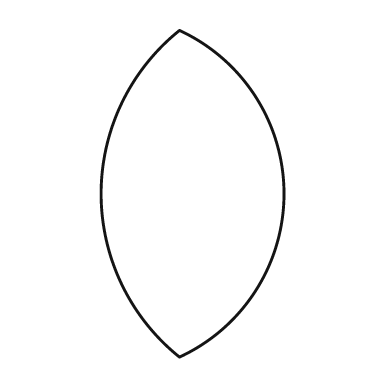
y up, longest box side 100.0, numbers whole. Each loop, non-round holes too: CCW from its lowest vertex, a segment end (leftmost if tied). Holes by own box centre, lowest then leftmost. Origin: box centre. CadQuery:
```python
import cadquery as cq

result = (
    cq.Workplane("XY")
    .moveTo(-4.0, -50.0)
    .threePointArc((28.0, 0.0), (-4.0, 50.0))
    .threePointArc((-28.0, 0.0), (-4.0, -50.0))
    .close()
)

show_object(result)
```